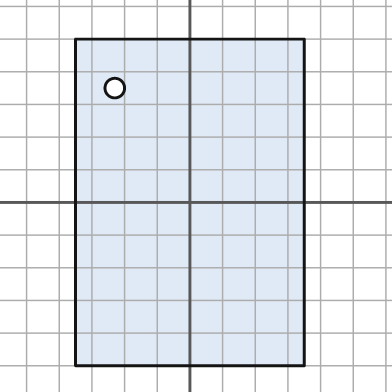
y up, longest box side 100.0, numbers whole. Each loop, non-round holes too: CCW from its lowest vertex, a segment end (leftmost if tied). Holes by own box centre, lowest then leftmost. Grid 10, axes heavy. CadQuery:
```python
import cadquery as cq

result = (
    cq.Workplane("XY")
    .moveTo(-35.0, -50.0)
    .lineTo(35.0, -50.0)
    .lineTo(35.0, 50.0)
    .lineTo(-35.0, 50.0)
    .close()
    .moveTo(-23.0, 35.0)
    .circle(3.0)
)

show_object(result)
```